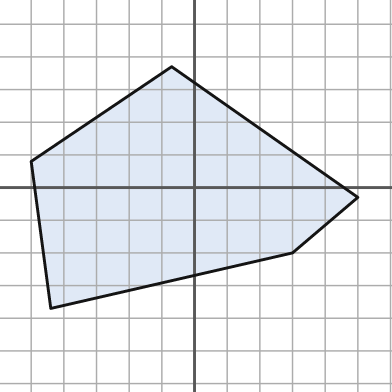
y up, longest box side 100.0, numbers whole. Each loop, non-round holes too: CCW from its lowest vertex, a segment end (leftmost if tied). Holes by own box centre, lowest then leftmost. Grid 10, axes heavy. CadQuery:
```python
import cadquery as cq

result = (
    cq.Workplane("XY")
    .moveTo(-44.0, -37.0)
    .lineTo(30.0, -20.0)
    .lineTo(50.0, -3.0)
    .lineTo(-7.0, 37.0)
    .lineTo(-50.0, 8.0)
    .close()
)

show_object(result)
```